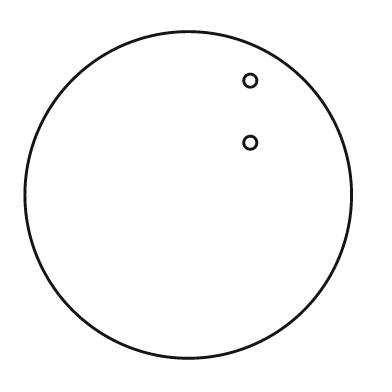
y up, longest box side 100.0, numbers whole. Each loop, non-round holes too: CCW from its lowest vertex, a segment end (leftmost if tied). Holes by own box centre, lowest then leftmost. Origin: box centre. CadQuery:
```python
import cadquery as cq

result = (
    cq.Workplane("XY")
    .moveTo(0.0, 0.0)
    .circle(50.0)
    .moveTo(19.0, 16.0)
    .circle(2.0)
    .moveTo(19.0, 35.0)
    .circle(2.0)
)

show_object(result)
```